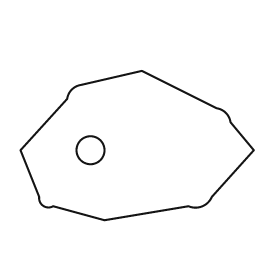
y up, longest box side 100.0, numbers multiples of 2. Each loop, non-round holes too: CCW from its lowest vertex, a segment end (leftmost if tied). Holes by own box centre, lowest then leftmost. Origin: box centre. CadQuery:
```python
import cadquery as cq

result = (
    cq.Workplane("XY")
    .moveTo(-14.0, -32.0)
    .lineTo(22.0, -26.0)
    .threePointArc((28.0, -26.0), (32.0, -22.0))
    .lineTo(50.0, -2.0)
    .lineTo(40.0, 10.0)
    .threePointArc((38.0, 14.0), (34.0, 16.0))
    .lineTo(2.0, 32.0)
    .lineTo(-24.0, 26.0)
    .threePointArc((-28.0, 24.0), (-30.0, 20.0))
    .lineTo(-50.0, -2.0)
    .lineTo(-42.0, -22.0)
    .threePointArc((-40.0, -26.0), (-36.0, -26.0))
    .close()
    .moveTo(-20.0, -2.0)
    .circle(6.0)
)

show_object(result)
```